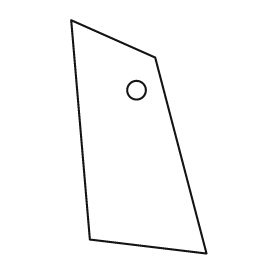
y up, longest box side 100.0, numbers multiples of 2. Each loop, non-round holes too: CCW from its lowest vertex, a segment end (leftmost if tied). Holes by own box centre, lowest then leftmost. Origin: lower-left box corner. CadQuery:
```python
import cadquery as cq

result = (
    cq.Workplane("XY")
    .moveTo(58.0, 0.0)
    .lineTo(36.0, 84.0)
    .lineTo(0.0, 100.0)
    .lineTo(8.0, 6.0)
    .close()
    .moveTo(28.0, 70.0)
    .circle(4.0)
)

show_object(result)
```